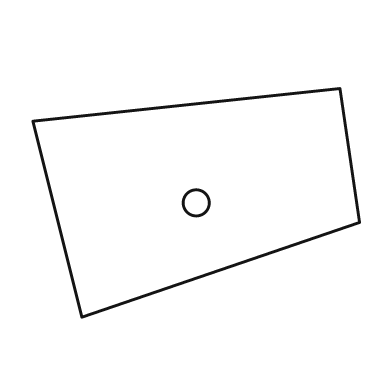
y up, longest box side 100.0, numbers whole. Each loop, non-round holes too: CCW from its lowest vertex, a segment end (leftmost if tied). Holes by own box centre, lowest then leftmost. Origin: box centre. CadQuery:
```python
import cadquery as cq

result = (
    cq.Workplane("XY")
    .moveTo(-35.0, -35.0)
    .lineTo(50.0, -6.0)
    .lineTo(44.0, 35.0)
    .lineTo(-50.0, 25.0)
    .close()
    .moveTo(0.0, 0.0)
    .circle(4.0)
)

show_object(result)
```